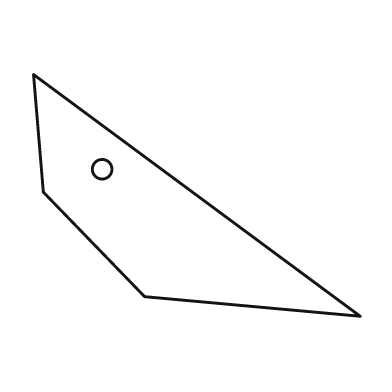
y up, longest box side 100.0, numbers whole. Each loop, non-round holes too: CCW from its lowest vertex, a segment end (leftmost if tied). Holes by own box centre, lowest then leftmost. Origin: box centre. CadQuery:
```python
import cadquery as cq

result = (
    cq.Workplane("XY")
    .moveTo(50.0, -37.0)
    .lineTo(-50.0, 37.0)
    .lineTo(-47.0, 1.0)
    .lineTo(-16.0, -31.0)
    .close()
    .moveTo(-29.0, 8.0)
    .circle(3.0)
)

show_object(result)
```